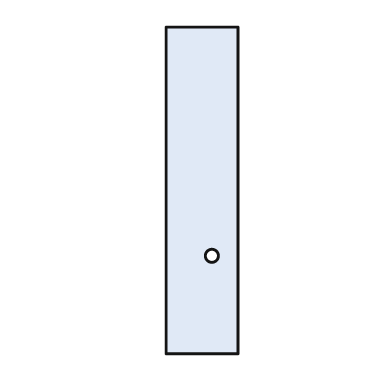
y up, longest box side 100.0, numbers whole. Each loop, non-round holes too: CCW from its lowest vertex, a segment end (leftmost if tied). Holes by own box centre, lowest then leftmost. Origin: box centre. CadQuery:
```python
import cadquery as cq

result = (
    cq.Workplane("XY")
    .moveTo(-11.0, -50.0)
    .lineTo(11.0, -50.0)
    .lineTo(11.0, 50.0)
    .lineTo(-11.0, 50.0)
    .close()
    .moveTo(3.0, -20.0)
    .circle(2.0)
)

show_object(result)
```